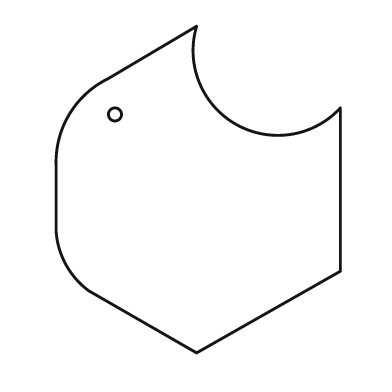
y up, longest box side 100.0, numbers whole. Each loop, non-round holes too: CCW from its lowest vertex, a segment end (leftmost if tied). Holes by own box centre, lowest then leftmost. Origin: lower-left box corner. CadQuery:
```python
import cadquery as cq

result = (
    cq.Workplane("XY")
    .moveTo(43.0, 0.0)
    .lineTo(87.0, 25.0)
    .lineTo(87.0, 75.0)
    .threePointArc((55.0, 70.0), (43.0, 100.0))
    .lineTo(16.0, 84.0)
    .threePointArc((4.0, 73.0), (0.0, 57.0))
    .lineTo(0.0, 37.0)
    .threePointArc((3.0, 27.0), (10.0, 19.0))
    .close()
    .moveTo(18.0, 73.0)
    .circle(2.0)
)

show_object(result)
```